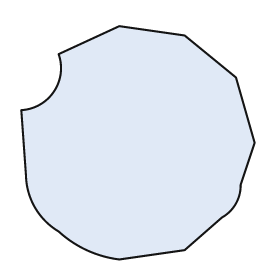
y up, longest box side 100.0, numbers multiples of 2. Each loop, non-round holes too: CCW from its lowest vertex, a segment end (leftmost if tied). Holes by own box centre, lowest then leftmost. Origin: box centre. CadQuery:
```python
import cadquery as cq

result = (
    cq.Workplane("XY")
    .moveTo(-8.0, -50.0)
    .lineTo(20.0, -46.0)
    .lineTo(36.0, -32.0)
    .threePointArc((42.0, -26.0), (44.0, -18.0))
    .lineTo(50.0, 0.0)
    .lineTo(42.0, 28.0)
    .lineTo(20.0, 46.0)
    .lineTo(-8.0, 50.0)
    .lineTo(-34.0, 38.0)
    .threePointArc((-36.0, 22.0), (-50.0, 14.0))
    .lineTo(-48.0, -14.0)
    .threePointArc((-44.0, -28.0), (-34.0, -38.0))
    .threePointArc((-22.0, -46.0), (-8.0, -50.0))
    .close()
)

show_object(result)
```